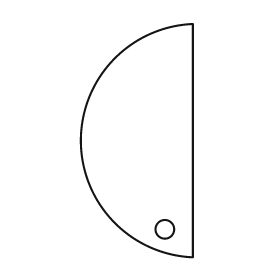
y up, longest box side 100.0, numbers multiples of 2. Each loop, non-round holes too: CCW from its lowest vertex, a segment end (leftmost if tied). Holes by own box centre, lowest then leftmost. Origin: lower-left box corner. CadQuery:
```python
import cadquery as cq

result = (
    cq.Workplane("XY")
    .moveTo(48.0, 0.0)
    .lineTo(48.0, 100.0)
    .threePointArc((0.0, 50.0), (48.0, 0.0))
    .close()
    .moveTo(36.0, 12.0)
    .circle(4.0)
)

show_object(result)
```